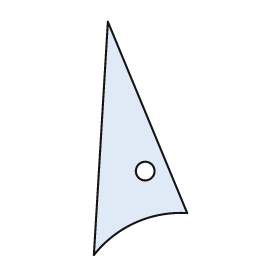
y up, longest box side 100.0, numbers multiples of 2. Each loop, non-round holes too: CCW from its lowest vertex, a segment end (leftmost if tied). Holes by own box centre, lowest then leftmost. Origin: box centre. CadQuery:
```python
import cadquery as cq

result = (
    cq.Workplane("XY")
    .moveTo(-20.0, -50.0)
    .threePointArc((-2.0, -36.0), (20.0, -32.0))
    .lineTo(-14.0, 50.0)
    .close()
    .moveTo(2.0, -14.0)
    .circle(4.0)
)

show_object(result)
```